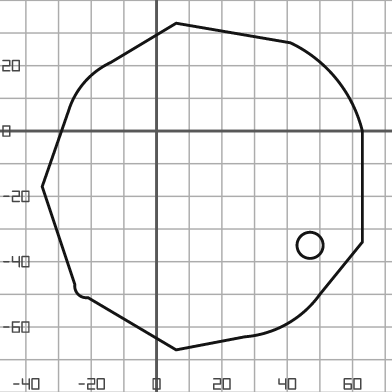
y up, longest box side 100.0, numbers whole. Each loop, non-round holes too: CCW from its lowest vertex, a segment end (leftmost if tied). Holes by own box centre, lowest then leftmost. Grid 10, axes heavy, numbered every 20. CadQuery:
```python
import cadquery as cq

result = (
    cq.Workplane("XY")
    .moveTo(6.0, -67.0)
    .lineTo(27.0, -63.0)
    .threePointArc((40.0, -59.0), (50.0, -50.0))
    .lineTo(63.0, -34.0)
    .lineTo(63.0, 0.0)
    .threePointArc((55.0, 16.0), (41.0, 27.0))
    .lineTo(6.0, 33.0)
    .lineTo(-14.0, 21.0)
    .threePointArc((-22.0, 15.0), (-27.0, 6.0))
    .lineTo(-35.0, -17.0)
    .lineTo(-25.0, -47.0)
    .threePointArc((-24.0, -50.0), (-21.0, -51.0))
    .close()
    .moveTo(47.0, -35.0)
    .circle(4.0)
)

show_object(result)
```